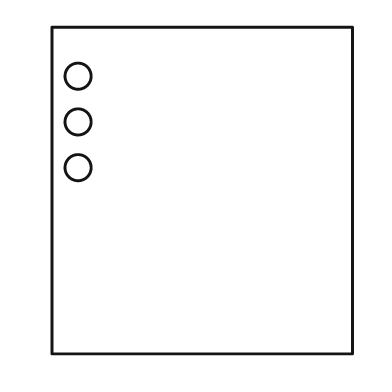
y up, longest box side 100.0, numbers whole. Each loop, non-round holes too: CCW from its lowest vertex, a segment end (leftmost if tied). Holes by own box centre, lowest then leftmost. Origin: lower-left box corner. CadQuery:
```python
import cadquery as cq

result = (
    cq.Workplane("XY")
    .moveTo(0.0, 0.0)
    .lineTo(92.0, 0.0)
    .lineTo(92.0, 100.0)
    .lineTo(0.0, 100.0)
    .close()
    .moveTo(8.0, 57.0)
    .circle(4.0)
    .moveTo(8.0, 71.0)
    .circle(4.0)
    .moveTo(8.0, 85.0)
    .circle(4.0)
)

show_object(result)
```